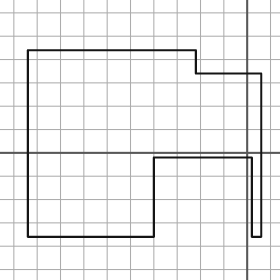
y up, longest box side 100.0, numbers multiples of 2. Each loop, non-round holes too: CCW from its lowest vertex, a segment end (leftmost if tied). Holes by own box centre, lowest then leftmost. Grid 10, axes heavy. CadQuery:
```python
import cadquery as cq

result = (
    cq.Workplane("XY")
    .moveTo(-94.0, -36.0)
    .lineTo(-40.0, -36.0)
    .lineTo(-40.0, -2.0)
    .lineTo(2.0, -2.0)
    .lineTo(2.0, -36.0)
    .lineTo(6.0, -36.0)
    .lineTo(6.0, 34.0)
    .lineTo(-22.0, 34.0)
    .lineTo(-22.0, 44.0)
    .lineTo(-94.0, 44.0)
    .close()
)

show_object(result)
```